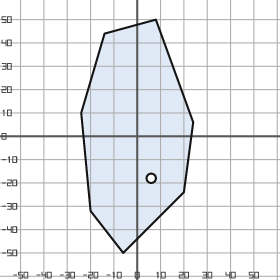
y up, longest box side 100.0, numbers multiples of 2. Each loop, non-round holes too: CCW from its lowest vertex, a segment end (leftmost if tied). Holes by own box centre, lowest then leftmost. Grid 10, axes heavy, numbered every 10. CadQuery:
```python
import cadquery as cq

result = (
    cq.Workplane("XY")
    .moveTo(-6.0, -50.0)
    .lineTo(20.0, -24.0)
    .lineTo(24.0, 6.0)
    .lineTo(8.0, 50.0)
    .lineTo(-14.0, 44.0)
    .lineTo(-24.0, 10.0)
    .lineTo(-20.0, -32.0)
    .close()
    .moveTo(6.0, -18.0)
    .circle(2.0)
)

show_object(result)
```